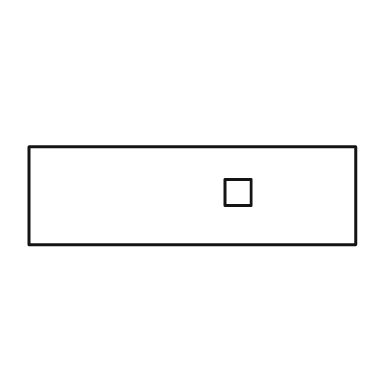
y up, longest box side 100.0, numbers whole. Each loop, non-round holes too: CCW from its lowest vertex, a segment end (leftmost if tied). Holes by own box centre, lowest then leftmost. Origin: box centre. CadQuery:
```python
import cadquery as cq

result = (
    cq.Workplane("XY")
    .moveTo(-50.0, -15.0)
    .lineTo(50.0, -15.0)
    .lineTo(50.0, 15.0)
    .lineTo(-50.0, 15.0)
    .close()
    .moveTo(10.0, -3.0)
    .lineTo(18.0, -3.0)
    .lineTo(18.0, 5.0)
    .lineTo(10.0, 5.0)
    .close()
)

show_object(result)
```